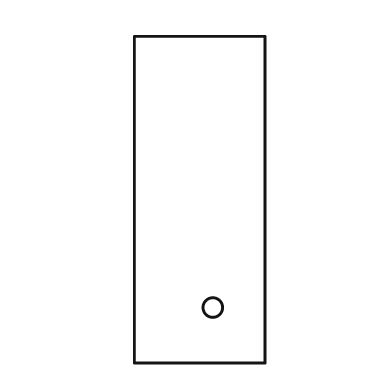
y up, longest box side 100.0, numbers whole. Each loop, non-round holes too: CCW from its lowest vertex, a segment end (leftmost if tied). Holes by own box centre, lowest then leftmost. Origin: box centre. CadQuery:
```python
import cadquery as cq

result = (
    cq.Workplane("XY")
    .moveTo(-20.0, -50.0)
    .lineTo(20.0, -50.0)
    .lineTo(20.0, 50.0)
    .lineTo(-20.0, 50.0)
    .close()
    .moveTo(4.0, -33.0)
    .circle(3.0)
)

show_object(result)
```